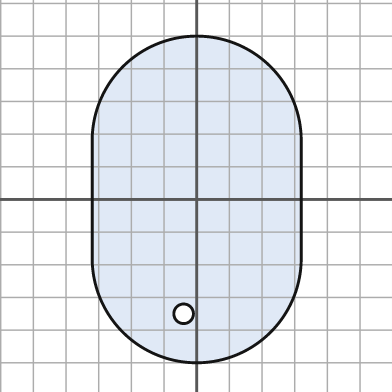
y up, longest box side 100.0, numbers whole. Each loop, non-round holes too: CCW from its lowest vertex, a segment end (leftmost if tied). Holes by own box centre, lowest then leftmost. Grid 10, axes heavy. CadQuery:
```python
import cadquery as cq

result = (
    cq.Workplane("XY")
    .moveTo(-32.0, -18.0)
    .threePointArc((0.0, -50.0), (32.0, -18.0))
    .lineTo(32.0, 18.0)
    .threePointArc((0.0, 50.0), (-32.0, 18.0))
    .close()
    .moveTo(-4.0, -35.0)
    .circle(3.0)
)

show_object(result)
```